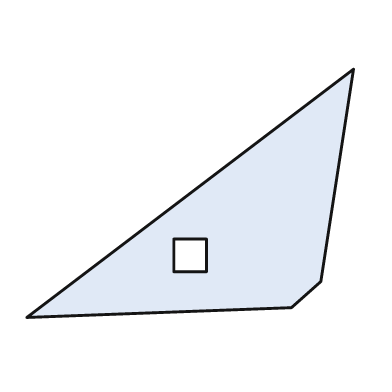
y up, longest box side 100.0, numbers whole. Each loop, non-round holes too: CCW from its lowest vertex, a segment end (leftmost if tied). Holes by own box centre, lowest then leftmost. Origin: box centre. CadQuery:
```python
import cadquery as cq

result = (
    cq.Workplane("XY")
    .moveTo(-50.0, -38.0)
    .lineTo(31.0, -35.0)
    .lineTo(40.0, -27.0)
    .lineTo(50.0, 38.0)
    .close()
    .moveTo(-5.0, -24.0)
    .lineTo(5.0, -24.0)
    .lineTo(5.0, -14.0)
    .lineTo(-5.0, -14.0)
    .close()
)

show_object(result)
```